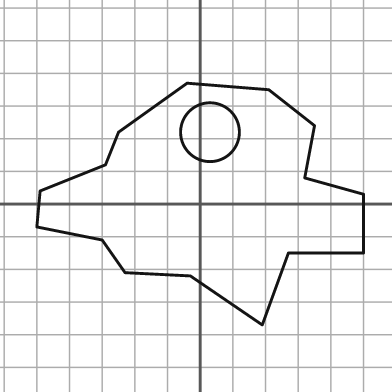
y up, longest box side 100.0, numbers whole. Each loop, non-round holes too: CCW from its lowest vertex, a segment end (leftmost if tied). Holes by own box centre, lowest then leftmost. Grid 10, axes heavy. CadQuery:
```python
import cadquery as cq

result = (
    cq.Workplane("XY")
    .moveTo(19.0, -37.0)
    .lineTo(27.0, -15.0)
    .lineTo(50.0, -15.0)
    .lineTo(50.0, 3.0)
    .lineTo(32.0, 8.0)
    .lineTo(35.0, 24.0)
    .lineTo(21.0, 35.0)
    .lineTo(-4.0, 37.0)
    .lineTo(-25.0, 22.0)
    .lineTo(-29.0, 12.0)
    .lineTo(-49.0, 4.0)
    .lineTo(-50.0, -7.0)
    .lineTo(-30.0, -11.0)
    .lineTo(-23.0, -21.0)
    .lineTo(-3.0, -22.0)
    .close()
    .moveTo(3.0, 22.0)
    .circle(9.0)
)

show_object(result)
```